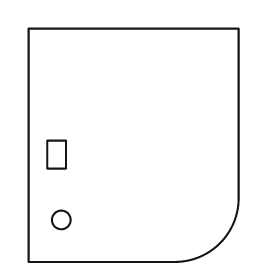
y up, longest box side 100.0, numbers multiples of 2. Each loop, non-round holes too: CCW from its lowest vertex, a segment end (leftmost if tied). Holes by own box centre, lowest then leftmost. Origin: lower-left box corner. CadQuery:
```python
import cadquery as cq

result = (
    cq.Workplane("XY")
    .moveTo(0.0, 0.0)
    .lineTo(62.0, 0.0)
    .threePointArc((82.0, 8.0), (90.0, 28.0))
    .lineTo(90.0, 100.0)
    .lineTo(0.0, 100.0)
    .close()
    .moveTo(14.0, 18.0)
    .circle(4.0)
    .moveTo(8.0, 40.0)
    .lineTo(16.0, 40.0)
    .lineTo(16.0, 52.0)
    .lineTo(8.0, 52.0)
    .close()
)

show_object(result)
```